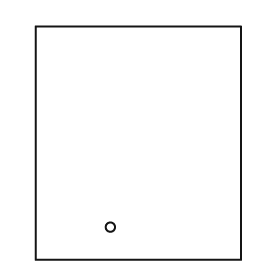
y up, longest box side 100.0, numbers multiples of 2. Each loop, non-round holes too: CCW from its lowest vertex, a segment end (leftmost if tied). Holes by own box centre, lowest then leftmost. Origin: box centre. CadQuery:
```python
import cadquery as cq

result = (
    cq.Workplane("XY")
    .moveTo(-44.0, -50.0)
    .lineTo(44.0, -50.0)
    .lineTo(44.0, 50.0)
    .lineTo(-44.0, 50.0)
    .close()
    .moveTo(-12.0, -36.0)
    .circle(2.0)
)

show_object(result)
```